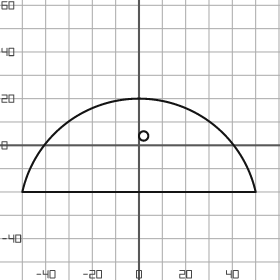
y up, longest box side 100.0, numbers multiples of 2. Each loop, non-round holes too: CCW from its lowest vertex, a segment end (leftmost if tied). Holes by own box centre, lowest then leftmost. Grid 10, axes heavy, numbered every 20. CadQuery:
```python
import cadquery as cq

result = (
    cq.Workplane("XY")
    .moveTo(-50.0, -20.0)
    .lineTo(50.0, -20.0)
    .threePointArc((0.0, 20.0), (-50.0, -20.0))
    .close()
    .moveTo(2.0, 4.0)
    .circle(2.0)
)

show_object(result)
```